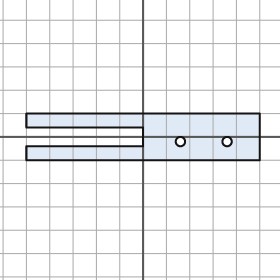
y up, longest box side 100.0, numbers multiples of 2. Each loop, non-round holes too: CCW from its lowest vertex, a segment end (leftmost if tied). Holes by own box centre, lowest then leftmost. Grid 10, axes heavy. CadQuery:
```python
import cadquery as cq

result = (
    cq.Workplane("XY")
    .moveTo(-50.0, -10.0)
    .lineTo(50.0, -10.0)
    .lineTo(50.0, 10.0)
    .lineTo(-50.0, 10.0)
    .lineTo(-50.0, 4.0)
    .lineTo(0.0, 4.0)
    .lineTo(0.0, -4.0)
    .lineTo(-50.0, -4.0)
    .close()
    .moveTo(16.0, -2.0)
    .circle(2.0)
    .moveTo(36.0, -2.0)
    .circle(2.0)
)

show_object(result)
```